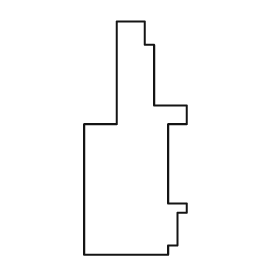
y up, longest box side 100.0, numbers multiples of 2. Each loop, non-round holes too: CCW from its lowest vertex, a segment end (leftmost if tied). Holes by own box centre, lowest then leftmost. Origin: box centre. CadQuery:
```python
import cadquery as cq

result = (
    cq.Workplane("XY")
    .moveTo(-22.0, -50.0)
    .lineTo(14.0, -50.0)
    .lineTo(14.0, -46.0)
    .lineTo(18.0, -46.0)
    .lineTo(18.0, -32.0)
    .lineTo(22.0, -32.0)
    .lineTo(22.0, -28.0)
    .lineTo(14.0, -28.0)
    .lineTo(14.0, 6.0)
    .lineTo(22.0, 6.0)
    .lineTo(22.0, 14.0)
    .lineTo(8.0, 14.0)
    .lineTo(8.0, 40.0)
    .lineTo(4.0, 40.0)
    .lineTo(4.0, 50.0)
    .lineTo(-8.0, 50.0)
    .lineTo(-8.0, 6.0)
    .lineTo(-22.0, 6.0)
    .close()
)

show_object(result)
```